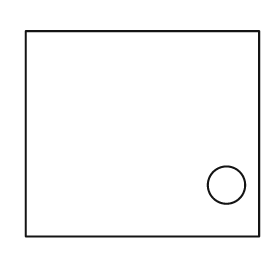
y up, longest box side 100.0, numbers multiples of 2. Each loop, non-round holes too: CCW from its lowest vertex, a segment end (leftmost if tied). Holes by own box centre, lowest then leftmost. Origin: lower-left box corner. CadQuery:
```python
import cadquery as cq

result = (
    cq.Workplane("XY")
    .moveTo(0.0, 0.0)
    .lineTo(100.0, 0.0)
    .lineTo(100.0, 88.0)
    .lineTo(0.0, 88.0)
    .close()
    .moveTo(86.0, 22.0)
    .circle(8.0)
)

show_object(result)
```